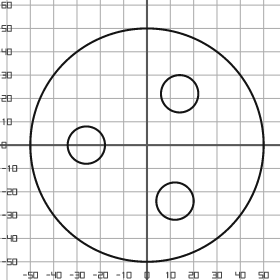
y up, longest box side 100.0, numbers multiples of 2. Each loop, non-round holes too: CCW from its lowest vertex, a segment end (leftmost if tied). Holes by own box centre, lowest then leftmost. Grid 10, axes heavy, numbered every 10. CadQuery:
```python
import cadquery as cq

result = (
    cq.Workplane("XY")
    .moveTo(0.0, 0.0)
    .circle(50.0)
    .moveTo(12.0, -24.0)
    .circle(8.0)
    .moveTo(-26.0, 0.0)
    .circle(8.0)
    .moveTo(14.0, 22.0)
    .circle(8.0)
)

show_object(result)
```